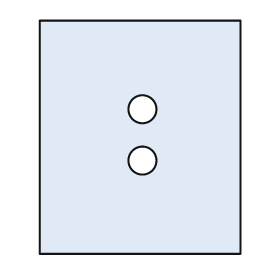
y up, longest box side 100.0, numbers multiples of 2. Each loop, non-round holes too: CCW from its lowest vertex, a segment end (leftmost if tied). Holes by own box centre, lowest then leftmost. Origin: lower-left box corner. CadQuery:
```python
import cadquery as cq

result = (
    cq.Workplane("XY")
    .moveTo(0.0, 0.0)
    .lineTo(86.0, 0.0)
    .lineTo(86.0, 100.0)
    .lineTo(0.0, 100.0)
    .close()
    .moveTo(44.0, 40.0)
    .circle(6.0)
    .moveTo(44.0, 62.0)
    .circle(6.0)
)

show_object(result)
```